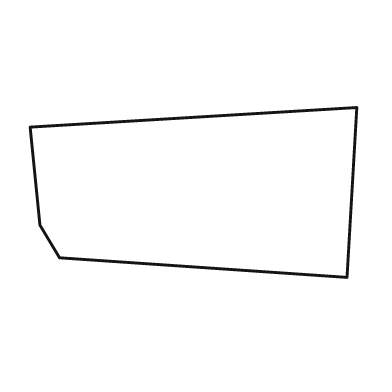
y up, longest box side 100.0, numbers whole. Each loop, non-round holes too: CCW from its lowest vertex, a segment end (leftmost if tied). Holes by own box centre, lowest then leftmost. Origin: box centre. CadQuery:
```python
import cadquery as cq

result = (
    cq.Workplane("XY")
    .moveTo(47.0, -26.0)
    .lineTo(50.0, 26.0)
    .lineTo(-50.0, 20.0)
    .lineTo(-47.0, -10.0)
    .lineTo(-41.0, -20.0)
    .close()
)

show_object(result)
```